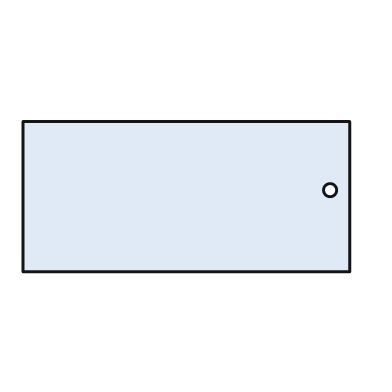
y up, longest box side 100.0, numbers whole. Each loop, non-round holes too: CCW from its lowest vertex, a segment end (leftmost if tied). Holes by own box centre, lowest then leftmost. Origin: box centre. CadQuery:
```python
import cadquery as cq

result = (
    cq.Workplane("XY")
    .moveTo(-50.0, -23.0)
    .lineTo(50.0, -23.0)
    .lineTo(50.0, 23.0)
    .lineTo(-50.0, 23.0)
    .close()
    .moveTo(44.0, 2.0)
    .circle(2.0)
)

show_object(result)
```